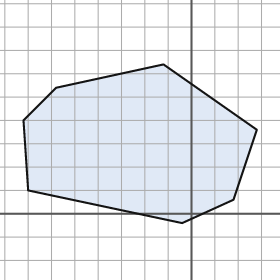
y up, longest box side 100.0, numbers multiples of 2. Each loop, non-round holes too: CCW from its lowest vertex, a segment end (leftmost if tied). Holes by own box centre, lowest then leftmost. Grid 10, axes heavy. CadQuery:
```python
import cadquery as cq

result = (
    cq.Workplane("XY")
    .moveTo(-4.0, -4.0)
    .lineTo(18.0, 6.0)
    .lineTo(28.0, 36.0)
    .lineTo(-12.0, 64.0)
    .lineTo(-58.0, 54.0)
    .lineTo(-72.0, 40.0)
    .lineTo(-70.0, 10.0)
    .close()
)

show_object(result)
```